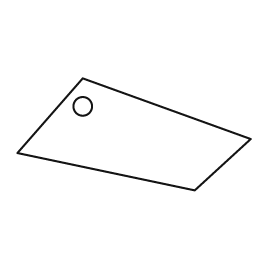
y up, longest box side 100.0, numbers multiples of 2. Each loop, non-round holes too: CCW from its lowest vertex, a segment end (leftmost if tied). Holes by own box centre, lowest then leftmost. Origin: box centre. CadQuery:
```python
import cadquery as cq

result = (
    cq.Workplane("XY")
    .moveTo(26.0, -24.0)
    .lineTo(50.0, -2.0)
    .lineTo(-22.0, 24.0)
    .lineTo(-50.0, -8.0)
    .close()
    .moveTo(-22.0, 12.0)
    .circle(4.0)
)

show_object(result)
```